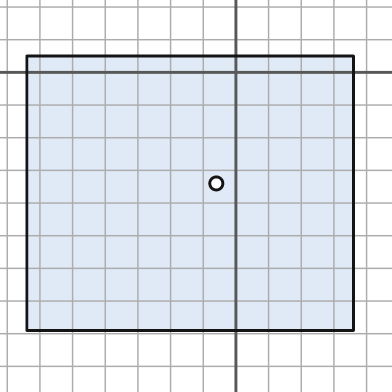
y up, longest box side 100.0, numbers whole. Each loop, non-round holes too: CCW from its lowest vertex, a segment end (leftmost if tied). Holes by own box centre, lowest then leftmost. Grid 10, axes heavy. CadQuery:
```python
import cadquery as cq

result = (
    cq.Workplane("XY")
    .moveTo(-64.0, -79.0)
    .lineTo(36.0, -79.0)
    .lineTo(36.0, 5.0)
    .lineTo(-64.0, 5.0)
    .close()
    .moveTo(-6.0, -34.0)
    .circle(2.0)
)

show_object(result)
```